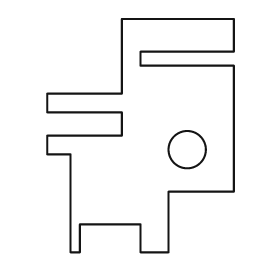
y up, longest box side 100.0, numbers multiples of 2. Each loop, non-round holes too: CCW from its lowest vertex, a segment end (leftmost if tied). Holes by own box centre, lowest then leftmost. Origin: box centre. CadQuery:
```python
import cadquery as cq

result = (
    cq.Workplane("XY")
    .moveTo(-30.0, -50.0)
    .lineTo(-26.0, -50.0)
    .lineTo(-26.0, -38.0)
    .lineTo(0.0, -38.0)
    .lineTo(0.0, -50.0)
    .lineTo(12.0, -50.0)
    .lineTo(12.0, -24.0)
    .lineTo(40.0, -24.0)
    .lineTo(40.0, 30.0)
    .lineTo(0.0, 30.0)
    .lineTo(0.0, 36.0)
    .lineTo(40.0, 36.0)
    .lineTo(40.0, 50.0)
    .lineTo(-8.0, 50.0)
    .lineTo(-8.0, 18.0)
    .lineTo(-40.0, 18.0)
    .lineTo(-40.0, 10.0)
    .lineTo(-8.0, 10.0)
    .lineTo(-8.0, 0.0)
    .lineTo(-40.0, 0.0)
    .lineTo(-40.0, -8.0)
    .lineTo(-30.0, -8.0)
    .close()
    .moveTo(20.0, -6.0)
    .circle(8.0)
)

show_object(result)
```